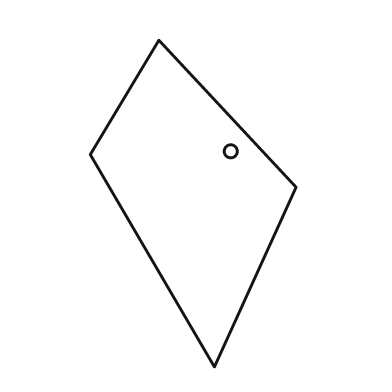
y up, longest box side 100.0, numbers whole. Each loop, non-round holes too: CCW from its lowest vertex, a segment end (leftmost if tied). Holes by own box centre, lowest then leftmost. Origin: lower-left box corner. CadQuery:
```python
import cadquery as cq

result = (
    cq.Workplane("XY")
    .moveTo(38.0, 0.0)
    .lineTo(63.0, 55.0)
    .lineTo(21.0, 100.0)
    .lineTo(0.0, 65.0)
    .close()
    .moveTo(43.0, 66.0)
    .circle(2.0)
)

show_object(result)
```